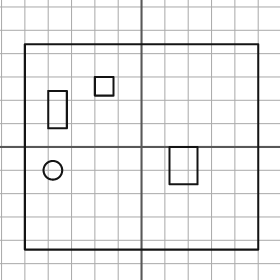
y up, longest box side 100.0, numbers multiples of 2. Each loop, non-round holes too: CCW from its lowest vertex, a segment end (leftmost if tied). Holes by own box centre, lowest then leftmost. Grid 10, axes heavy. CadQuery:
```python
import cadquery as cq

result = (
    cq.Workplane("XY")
    .moveTo(-50.0, -44.0)
    .lineTo(50.0, -44.0)
    .lineTo(50.0, 44.0)
    .lineTo(-50.0, 44.0)
    .close()
    .moveTo(-38.0, -10.0)
    .circle(4.0)
    .moveTo(12.0, -16.0)
    .lineTo(24.0, -16.0)
    .lineTo(24.0, 0.0)
    .lineTo(12.0, 0.0)
    .close()
    .moveTo(-40.0, 8.0)
    .lineTo(-32.0, 8.0)
    .lineTo(-32.0, 24.0)
    .lineTo(-40.0, 24.0)
    .close()
    .moveTo(-20.0, 22.0)
    .lineTo(-12.0, 22.0)
    .lineTo(-12.0, 30.0)
    .lineTo(-20.0, 30.0)
    .close()
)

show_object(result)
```